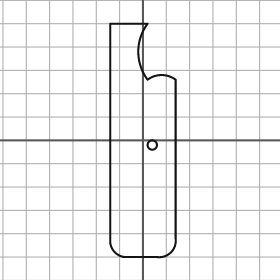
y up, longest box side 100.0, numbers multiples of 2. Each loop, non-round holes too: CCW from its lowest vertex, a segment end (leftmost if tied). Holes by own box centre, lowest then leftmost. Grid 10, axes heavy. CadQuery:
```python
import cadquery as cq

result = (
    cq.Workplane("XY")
    .moveTo(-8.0, -50.0)
    .lineTo(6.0, -50.0)
    .threePointArc((12.0, -48.0), (14.0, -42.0))
    .lineTo(14.0, 26.0)
    .threePointArc((8.0, 28.0), (2.0, 26.0))
    .threePointArc((-2.0, 38.0), (2.0, 50.0))
    .lineTo(-14.0, 50.0)
    .lineTo(-14.0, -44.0)
    .threePointArc((-12.0, -48.0), (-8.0, -50.0))
    .close()
    .moveTo(4.0, -2.0)
    .circle(2.0)
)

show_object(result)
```